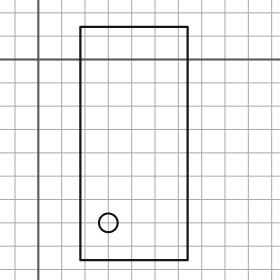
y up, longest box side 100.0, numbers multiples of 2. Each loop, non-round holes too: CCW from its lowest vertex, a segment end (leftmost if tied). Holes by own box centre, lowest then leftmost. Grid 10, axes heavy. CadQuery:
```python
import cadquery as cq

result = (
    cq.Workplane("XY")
    .moveTo(18.0, -86.0)
    .lineTo(64.0, -86.0)
    .lineTo(64.0, 14.0)
    .lineTo(18.0, 14.0)
    .close()
    .moveTo(30.0, -70.0)
    .circle(4.0)
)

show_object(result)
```